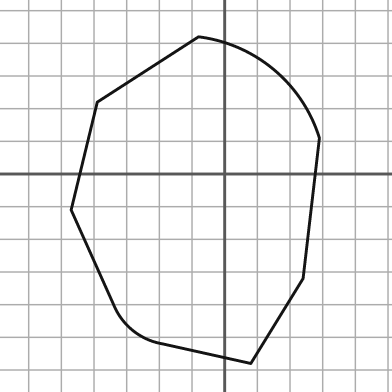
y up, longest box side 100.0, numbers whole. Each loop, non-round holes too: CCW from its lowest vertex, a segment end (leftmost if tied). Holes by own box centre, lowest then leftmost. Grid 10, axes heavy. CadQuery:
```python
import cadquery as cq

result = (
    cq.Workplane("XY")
    .moveTo(8.0, -58.0)
    .lineTo(24.0, -32.0)
    .lineTo(29.0, 11.0)
    .threePointArc((15.0, 32.0), (-8.0, 42.0))
    .lineTo(-39.0, 22.0)
    .lineTo(-47.0, -11.0)
    .lineTo(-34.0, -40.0)
    .threePointArc((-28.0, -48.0), (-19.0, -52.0))
    .close()
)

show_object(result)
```